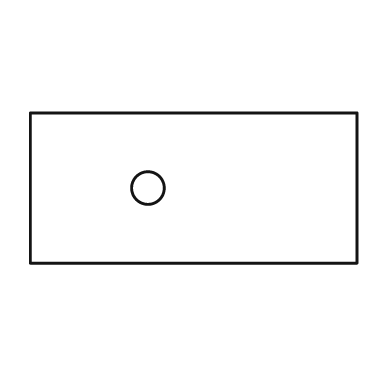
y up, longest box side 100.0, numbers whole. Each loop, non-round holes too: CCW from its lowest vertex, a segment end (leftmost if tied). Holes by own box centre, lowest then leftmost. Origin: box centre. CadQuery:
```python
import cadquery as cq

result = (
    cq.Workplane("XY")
    .moveTo(-50.0, -23.0)
    .lineTo(50.0, -23.0)
    .lineTo(50.0, 23.0)
    .lineTo(-50.0, 23.0)
    .close()
    .moveTo(-14.0, 0.0)
    .circle(5.0)
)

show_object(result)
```